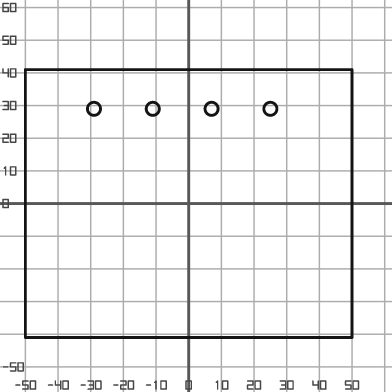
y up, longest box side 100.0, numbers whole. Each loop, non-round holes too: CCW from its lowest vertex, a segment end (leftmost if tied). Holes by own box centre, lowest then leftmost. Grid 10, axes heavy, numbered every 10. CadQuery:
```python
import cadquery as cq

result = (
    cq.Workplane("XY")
    .moveTo(-50.0, -41.0)
    .lineTo(50.0, -41.0)
    .lineTo(50.0, 41.0)
    .lineTo(-50.0, 41.0)
    .close()
    .moveTo(-29.0, 29.0)
    .circle(2.0)
    .moveTo(-11.0, 29.0)
    .circle(2.0)
    .moveTo(7.0, 29.0)
    .circle(2.0)
    .moveTo(25.0, 29.0)
    .circle(2.0)
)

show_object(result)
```